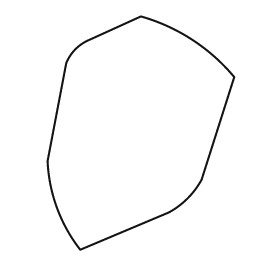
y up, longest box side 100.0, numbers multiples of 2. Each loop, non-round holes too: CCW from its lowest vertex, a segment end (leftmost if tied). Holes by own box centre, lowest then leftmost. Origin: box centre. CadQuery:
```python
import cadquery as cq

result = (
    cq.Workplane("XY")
    .moveTo(-26.0, -50.0)
    .lineTo(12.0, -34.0)
    .threePointArc((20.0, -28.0), (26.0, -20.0))
    .lineTo(40.0, 24.0)
    .threePointArc((22.0, 40.0), (0.0, 50.0))
    .lineTo(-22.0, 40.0)
    .threePointArc((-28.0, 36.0), (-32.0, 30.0))
    .lineTo(-40.0, -12.0)
    .threePointArc((-36.0, -32.0), (-26.0, -50.0))
    .close()
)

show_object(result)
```